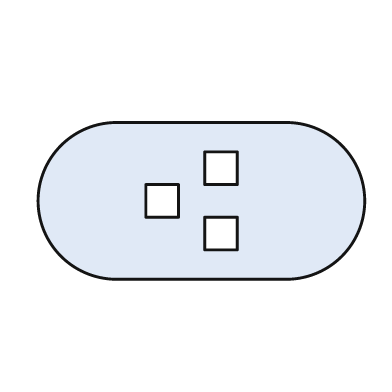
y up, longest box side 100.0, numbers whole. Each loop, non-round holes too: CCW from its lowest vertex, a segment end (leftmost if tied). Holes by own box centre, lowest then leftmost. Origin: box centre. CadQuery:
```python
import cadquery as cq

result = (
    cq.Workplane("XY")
    .moveTo(-26.0, -24.0)
    .lineTo(26.0, -24.0)
    .threePointArc((50.0, 0.0), (26.0, 24.0))
    .lineTo(-26.0, 24.0)
    .threePointArc((-50.0, 0.0), (-26.0, -24.0))
    .close()
    .moveTo(1.0, -15.0)
    .lineTo(11.0, -15.0)
    .lineTo(11.0, -5.0)
    .lineTo(1.0, -5.0)
    .close()
    .moveTo(-17.0, -5.0)
    .lineTo(-7.0, -5.0)
    .lineTo(-7.0, 5.0)
    .lineTo(-17.0, 5.0)
    .close()
    .moveTo(1.0, 5.0)
    .lineTo(11.0, 5.0)
    .lineTo(11.0, 15.0)
    .lineTo(1.0, 15.0)
    .close()
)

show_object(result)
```